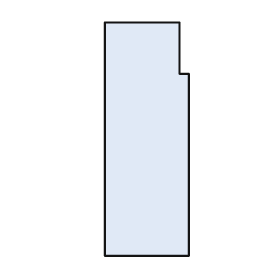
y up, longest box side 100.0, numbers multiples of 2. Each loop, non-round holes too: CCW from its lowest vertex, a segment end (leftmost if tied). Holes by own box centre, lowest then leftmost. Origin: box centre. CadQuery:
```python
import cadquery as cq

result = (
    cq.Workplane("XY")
    .moveTo(-18.0, -50.0)
    .lineTo(18.0, -50.0)
    .lineTo(18.0, 28.0)
    .lineTo(14.0, 28.0)
    .lineTo(14.0, 50.0)
    .lineTo(-18.0, 50.0)
    .close()
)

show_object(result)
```